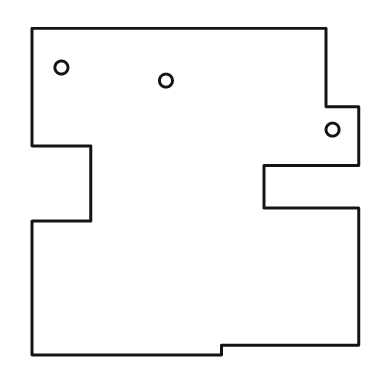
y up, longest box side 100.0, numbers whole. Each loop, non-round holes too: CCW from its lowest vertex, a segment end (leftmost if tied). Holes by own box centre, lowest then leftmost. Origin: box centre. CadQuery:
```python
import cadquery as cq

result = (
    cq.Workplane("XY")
    .moveTo(-50.0, -50.0)
    .lineTo(8.0, -50.0)
    .lineTo(8.0, -47.0)
    .lineTo(50.0, -47.0)
    .lineTo(50.0, -5.0)
    .lineTo(21.0, -5.0)
    .lineTo(21.0, 8.0)
    .lineTo(50.0, 8.0)
    .lineTo(50.0, 26.0)
    .lineTo(40.0, 26.0)
    .lineTo(40.0, 50.0)
    .lineTo(-50.0, 50.0)
    .lineTo(-50.0, 14.0)
    .lineTo(-32.0, 14.0)
    .lineTo(-32.0, -9.0)
    .lineTo(-50.0, -9.0)
    .close()
    .moveTo(42.0, 19.0)
    .circle(2.0)
    .moveTo(-9.0, 34.0)
    .circle(2.0)
    .moveTo(-41.0, 38.0)
    .circle(2.0)
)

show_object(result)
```